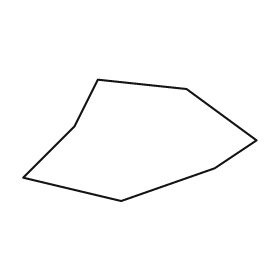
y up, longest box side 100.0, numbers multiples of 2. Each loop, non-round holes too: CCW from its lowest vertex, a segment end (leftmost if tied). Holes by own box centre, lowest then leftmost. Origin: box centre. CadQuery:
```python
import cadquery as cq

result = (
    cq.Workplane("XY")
    .moveTo(-8.0, -26.0)
    .lineTo(32.0, -12.0)
    .lineTo(50.0, 0.0)
    .lineTo(20.0, 22.0)
    .lineTo(-18.0, 26.0)
    .lineTo(-28.0, 6.0)
    .lineTo(-50.0, -16.0)
    .close()
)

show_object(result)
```